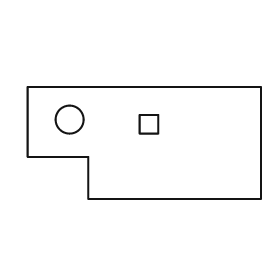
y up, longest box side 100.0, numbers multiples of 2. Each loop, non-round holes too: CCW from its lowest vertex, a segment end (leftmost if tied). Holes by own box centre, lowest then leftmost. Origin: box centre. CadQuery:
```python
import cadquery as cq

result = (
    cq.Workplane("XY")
    .moveTo(-24.0, -24.0)
    .lineTo(50.0, -24.0)
    .lineTo(50.0, 24.0)
    .lineTo(-50.0, 24.0)
    .lineTo(-50.0, -6.0)
    .lineTo(-24.0, -6.0)
    .close()
    .moveTo(-2.0, 4.0)
    .lineTo(6.0, 4.0)
    .lineTo(6.0, 12.0)
    .lineTo(-2.0, 12.0)
    .close()
    .moveTo(-32.0, 10.0)
    .circle(6.0)
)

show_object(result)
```